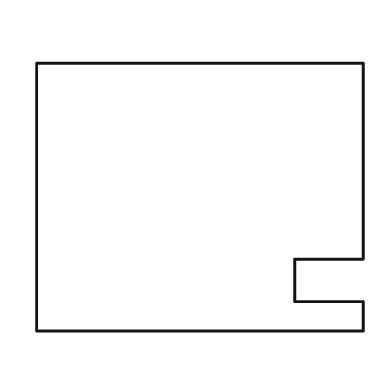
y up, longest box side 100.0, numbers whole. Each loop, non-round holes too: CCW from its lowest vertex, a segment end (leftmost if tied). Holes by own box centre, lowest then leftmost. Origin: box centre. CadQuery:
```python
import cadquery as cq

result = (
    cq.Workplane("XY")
    .moveTo(-50.0, -41.0)
    .lineTo(50.0, -41.0)
    .lineTo(50.0, -32.0)
    .lineTo(29.0, -32.0)
    .lineTo(29.0, -19.0)
    .lineTo(50.0, -19.0)
    .lineTo(50.0, 41.0)
    .lineTo(-50.0, 41.0)
    .close()
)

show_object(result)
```